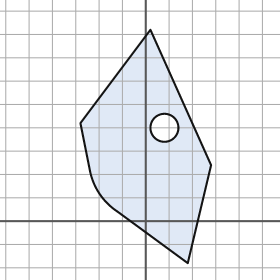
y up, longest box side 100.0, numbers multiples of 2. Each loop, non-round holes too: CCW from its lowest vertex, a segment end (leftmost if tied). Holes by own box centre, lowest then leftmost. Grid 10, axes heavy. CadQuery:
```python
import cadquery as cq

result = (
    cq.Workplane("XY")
    .moveTo(18.0, -18.0)
    .lineTo(28.0, 24.0)
    .lineTo(2.0, 82.0)
    .lineTo(-28.0, 42.0)
    .lineTo(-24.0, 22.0)
    .threePointArc((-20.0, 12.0), (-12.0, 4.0))
    .close()
    .moveTo(8.0, 40.0)
    .circle(6.0)
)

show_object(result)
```